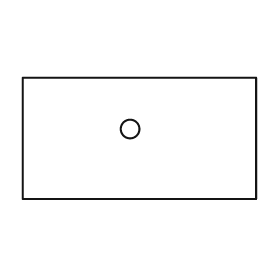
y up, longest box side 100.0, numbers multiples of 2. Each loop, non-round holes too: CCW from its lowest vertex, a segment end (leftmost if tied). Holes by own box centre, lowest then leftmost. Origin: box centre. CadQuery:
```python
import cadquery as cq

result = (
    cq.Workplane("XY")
    .moveTo(-50.0, -26.0)
    .lineTo(50.0, -26.0)
    .lineTo(50.0, 26.0)
    .lineTo(-50.0, 26.0)
    .close()
    .moveTo(-4.0, 4.0)
    .circle(4.0)
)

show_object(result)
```